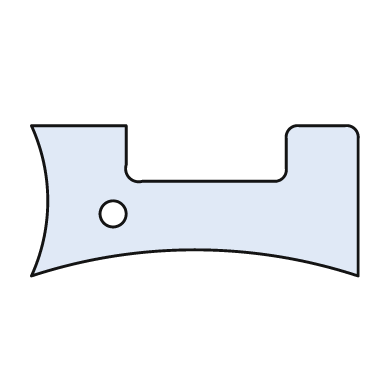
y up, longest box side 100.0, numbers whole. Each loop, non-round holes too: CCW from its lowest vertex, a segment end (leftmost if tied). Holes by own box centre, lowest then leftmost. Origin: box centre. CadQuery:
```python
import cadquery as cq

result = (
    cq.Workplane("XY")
    .moveTo(-50.0, -23.0)
    .threePointArc((0.0, -15.0), (50.0, -23.0))
    .lineTo(50.0, 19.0)
    .threePointArc((49.0, 22.0), (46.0, 23.0))
    .lineTo(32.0, 23.0)
    .threePointArc((29.0, 22.0), (28.0, 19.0))
    .lineTo(28.0, 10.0)
    .threePointArc((27.0, 7.0), (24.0, 6.0))
    .lineTo(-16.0, 6.0)
    .threePointArc((-20.0, 7.0), (-21.0, 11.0))
    .lineTo(-21.0, 23.0)
    .lineTo(-50.0, 23.0)
    .threePointArc((-45.0, 0.0), (-50.0, -23.0))
    .close()
    .moveTo(-25.0, -4.0)
    .circle(4.0)
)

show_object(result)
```